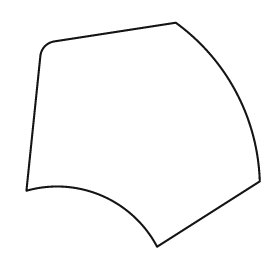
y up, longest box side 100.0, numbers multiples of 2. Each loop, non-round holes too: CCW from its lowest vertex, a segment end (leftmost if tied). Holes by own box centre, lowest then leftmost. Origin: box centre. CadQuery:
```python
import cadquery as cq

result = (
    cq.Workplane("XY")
    .moveTo(6.0, -48.0)
    .lineTo(50.0, -20.0)
    .threePointArc((40.0, 18.0), (14.0, 48.0))
    .lineTo(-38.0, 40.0)
    .threePointArc((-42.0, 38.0), (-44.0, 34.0))
    .lineTo(-50.0, -24.0)
    .threePointArc((-18.0, -26.0), (6.0, -48.0))
    .close()
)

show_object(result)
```